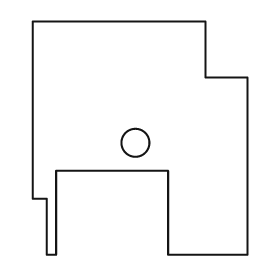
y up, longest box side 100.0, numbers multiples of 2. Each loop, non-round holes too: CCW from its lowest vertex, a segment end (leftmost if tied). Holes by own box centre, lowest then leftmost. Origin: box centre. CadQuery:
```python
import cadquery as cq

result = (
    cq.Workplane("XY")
    .moveTo(-40.0, -50.0)
    .lineTo(-36.0, -50.0)
    .lineTo(-36.0, -14.0)
    .lineTo(12.0, -14.0)
    .lineTo(12.0, -50.0)
    .lineTo(46.0, -50.0)
    .lineTo(46.0, 26.0)
    .lineTo(28.0, 26.0)
    .lineTo(28.0, 50.0)
    .lineTo(-46.0, 50.0)
    .lineTo(-46.0, -26.0)
    .lineTo(-40.0, -26.0)
    .close()
    .moveTo(-2.0, -2.0)
    .circle(6.0)
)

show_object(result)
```